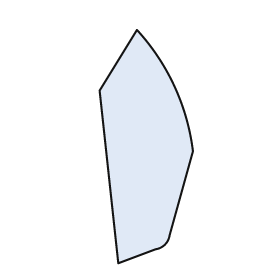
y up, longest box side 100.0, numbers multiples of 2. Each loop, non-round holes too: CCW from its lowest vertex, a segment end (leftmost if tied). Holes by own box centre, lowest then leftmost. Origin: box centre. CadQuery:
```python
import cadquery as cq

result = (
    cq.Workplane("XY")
    .moveTo(-12.0, -50.0)
    .lineTo(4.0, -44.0)
    .threePointArc((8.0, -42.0), (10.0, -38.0))
    .lineTo(20.0, -2.0)
    .threePointArc((12.0, 26.0), (-4.0, 50.0))
    .lineTo(-20.0, 24.0)
    .close()
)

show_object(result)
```